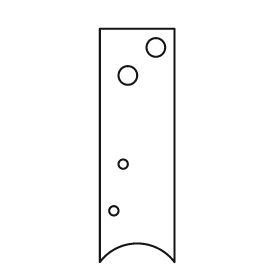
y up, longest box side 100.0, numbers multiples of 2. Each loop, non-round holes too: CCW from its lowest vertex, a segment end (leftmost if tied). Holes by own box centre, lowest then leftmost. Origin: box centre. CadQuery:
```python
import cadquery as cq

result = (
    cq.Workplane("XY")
    .moveTo(-16.0, -50.0)
    .threePointArc((0.0, -42.0), (16.0, -50.0))
    .lineTo(16.0, 50.0)
    .lineTo(-16.0, 50.0)
    .close()
    .moveTo(-10.0, -28.0)
    .circle(2.0)
    .moveTo(-6.0, -8.0)
    .circle(2.0)
    .moveTo(-4.0, 30.0)
    .circle(4.0)
    .moveTo(8.0, 42.0)
    .circle(4.0)
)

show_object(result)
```